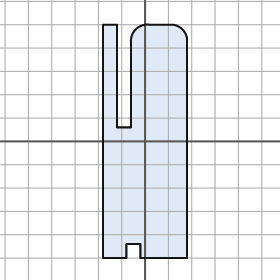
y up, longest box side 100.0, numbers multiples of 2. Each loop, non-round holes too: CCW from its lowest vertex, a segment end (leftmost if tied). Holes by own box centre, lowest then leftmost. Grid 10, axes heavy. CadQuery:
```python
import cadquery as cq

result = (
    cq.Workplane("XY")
    .moveTo(-18.0, -50.0)
    .lineTo(-8.0, -50.0)
    .lineTo(-8.0, -44.0)
    .lineTo(-2.0, -44.0)
    .lineTo(-2.0, -50.0)
    .lineTo(18.0, -50.0)
    .lineTo(18.0, 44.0)
    .threePointArc((16.0, 48.0), (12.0, 50.0))
    .lineTo(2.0, 50.0)
    .threePointArc((-4.0, 48.0), (-6.0, 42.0))
    .lineTo(-6.0, 6.0)
    .lineTo(-12.0, 6.0)
    .lineTo(-12.0, 50.0)
    .lineTo(-18.0, 50.0)
    .close()
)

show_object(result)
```